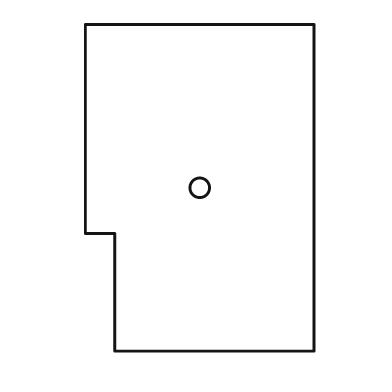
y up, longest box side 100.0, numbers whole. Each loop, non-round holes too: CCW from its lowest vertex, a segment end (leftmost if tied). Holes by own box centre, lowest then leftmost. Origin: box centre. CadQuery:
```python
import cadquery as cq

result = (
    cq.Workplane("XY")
    .moveTo(-26.0, -50.0)
    .lineTo(35.0, -50.0)
    .lineTo(35.0, 50.0)
    .lineTo(-35.0, 50.0)
    .lineTo(-35.0, -14.0)
    .lineTo(-26.0, -14.0)
    .close()
    .moveTo(0.0, 0.0)
    .circle(3.0)
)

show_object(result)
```